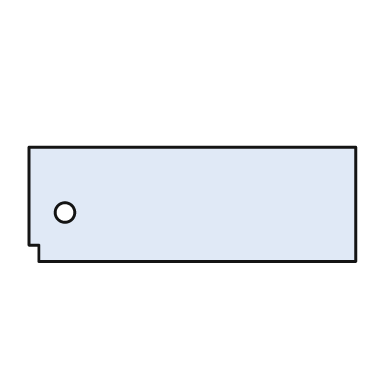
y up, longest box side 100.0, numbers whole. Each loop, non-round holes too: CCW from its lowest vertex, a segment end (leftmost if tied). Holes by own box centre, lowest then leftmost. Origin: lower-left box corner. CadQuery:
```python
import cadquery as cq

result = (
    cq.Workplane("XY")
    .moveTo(3.0, 0.0)
    .lineTo(100.0, 0.0)
    .lineTo(100.0, 35.0)
    .lineTo(0.0, 35.0)
    .lineTo(0.0, 5.0)
    .lineTo(3.0, 5.0)
    .close()
    .moveTo(11.0, 15.0)
    .circle(3.0)
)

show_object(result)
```